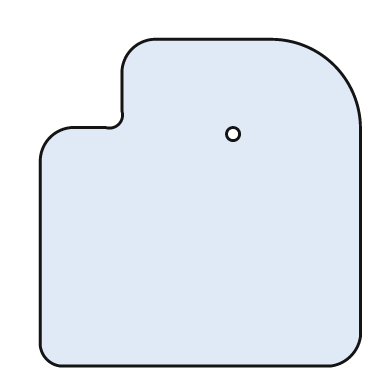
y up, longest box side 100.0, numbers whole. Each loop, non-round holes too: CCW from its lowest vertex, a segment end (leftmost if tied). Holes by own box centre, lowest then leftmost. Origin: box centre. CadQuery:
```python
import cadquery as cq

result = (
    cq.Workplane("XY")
    .moveTo(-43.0, -50.0)
    .lineTo(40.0, -50.0)
    .threePointArc((46.0, -47.0), (49.0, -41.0))
    .lineTo(49.0, 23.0)
    .threePointArc((41.0, 42.0), (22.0, 50.0))
    .lineTo(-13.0, 50.0)
    .threePointArc((-21.0, 47.0), (-24.0, 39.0))
    .lineTo(-24.0, 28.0)
    .threePointArc((-25.0, 24.0), (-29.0, 23.0))
    .lineTo(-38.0, 23.0)
    .threePointArc((-46.0, 20.0), (-49.0, 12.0))
    .lineTo(-49.0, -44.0)
    .threePointArc((-47.0, -48.0), (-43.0, -50.0))
    .close()
    .moveTo(10.0, 21.0)
    .circle(2.0)
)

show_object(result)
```